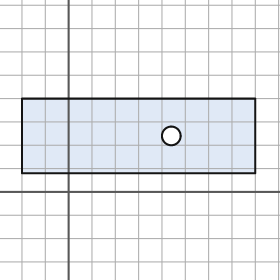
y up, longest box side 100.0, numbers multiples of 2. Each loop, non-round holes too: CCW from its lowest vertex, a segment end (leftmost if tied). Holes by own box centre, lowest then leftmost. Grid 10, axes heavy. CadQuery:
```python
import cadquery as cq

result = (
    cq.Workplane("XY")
    .moveTo(-20.0, 8.0)
    .lineTo(80.0, 8.0)
    .lineTo(80.0, 40.0)
    .lineTo(-20.0, 40.0)
    .close()
    .moveTo(44.0, 24.0)
    .circle(4.0)
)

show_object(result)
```